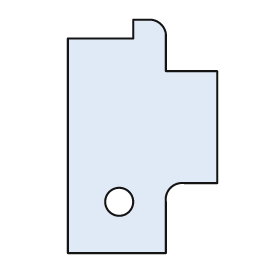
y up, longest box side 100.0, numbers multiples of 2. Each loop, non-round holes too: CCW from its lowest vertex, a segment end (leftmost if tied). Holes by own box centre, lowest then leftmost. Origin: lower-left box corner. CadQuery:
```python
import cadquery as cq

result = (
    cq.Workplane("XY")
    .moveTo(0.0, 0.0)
    .lineTo(42.0, 0.0)
    .lineTo(42.0, 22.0)
    .threePointArc((44.0, 28.0), (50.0, 30.0))
    .lineTo(64.0, 30.0)
    .lineTo(64.0, 78.0)
    .lineTo(42.0, 78.0)
    .lineTo(42.0, 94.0)
    .threePointArc((40.0, 98.0), (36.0, 100.0))
    .lineTo(28.0, 100.0)
    .lineTo(28.0, 92.0)
    .lineTo(0.0, 92.0)
    .close()
    .moveTo(22.0, 22.0)
    .circle(6.0)
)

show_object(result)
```